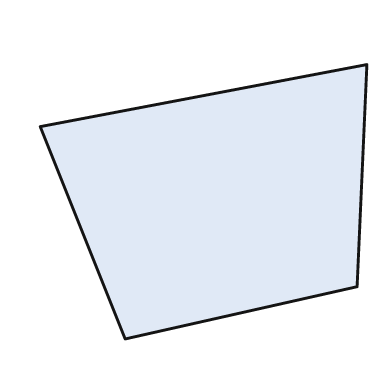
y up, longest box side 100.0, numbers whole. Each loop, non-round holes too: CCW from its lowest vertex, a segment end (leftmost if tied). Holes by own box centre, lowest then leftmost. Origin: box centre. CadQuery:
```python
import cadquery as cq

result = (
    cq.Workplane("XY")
    .moveTo(-24.0, -42.0)
    .lineTo(47.0, -26.0)
    .lineTo(50.0, 42.0)
    .lineTo(-50.0, 23.0)
    .close()
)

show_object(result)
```